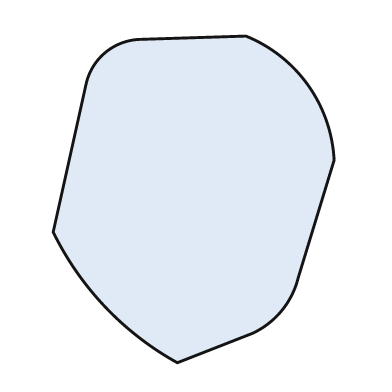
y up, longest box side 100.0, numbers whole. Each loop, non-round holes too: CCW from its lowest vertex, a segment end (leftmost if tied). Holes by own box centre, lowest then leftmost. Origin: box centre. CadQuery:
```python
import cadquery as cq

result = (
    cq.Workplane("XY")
    .moveTo(-5.0, -50.0)
    .lineTo(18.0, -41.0)
    .threePointArc((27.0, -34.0), (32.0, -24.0))
    .lineTo(43.0, 12.0)
    .threePointArc((35.0, 35.0), (16.0, 50.0))
    .lineTo(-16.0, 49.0)
    .threePointArc((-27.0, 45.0), (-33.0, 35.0))
    .lineTo(-43.0, -10.0)
    .threePointArc((-27.0, -33.0), (-5.0, -50.0))
    .close()
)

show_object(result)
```